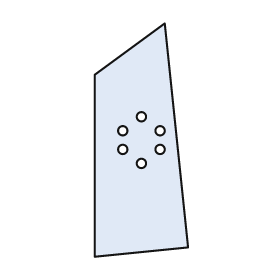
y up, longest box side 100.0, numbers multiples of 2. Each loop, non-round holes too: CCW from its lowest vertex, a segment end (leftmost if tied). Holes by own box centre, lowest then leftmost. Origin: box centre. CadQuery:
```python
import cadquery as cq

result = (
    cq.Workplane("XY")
    .moveTo(-20.0, -50.0)
    .lineTo(20.0, -46.0)
    .lineTo(10.0, 50.0)
    .lineTo(-20.0, 28.0)
    .close()
    .moveTo(0.0, -10.0)
    .circle(2.0)
    .moveTo(-8.0, -4.0)
    .circle(2.0)
    .moveTo(8.0, -4.0)
    .circle(2.0)
    .moveTo(-8.0, 4.0)
    .circle(2.0)
    .moveTo(8.0, 4.0)
    .circle(2.0)
    .moveTo(0.0, 10.0)
    .circle(2.0)
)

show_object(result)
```